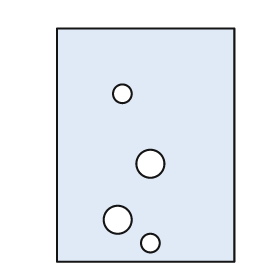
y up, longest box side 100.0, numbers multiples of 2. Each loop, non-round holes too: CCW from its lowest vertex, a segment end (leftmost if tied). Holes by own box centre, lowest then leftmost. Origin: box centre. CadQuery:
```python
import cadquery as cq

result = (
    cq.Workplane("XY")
    .moveTo(-38.0, -50.0)
    .lineTo(38.0, -50.0)
    .lineTo(38.0, 50.0)
    .lineTo(-38.0, 50.0)
    .close()
    .moveTo(2.0, -42.0)
    .circle(4.0)
    .moveTo(-12.0, -32.0)
    .circle(6.0)
    .moveTo(2.0, -8.0)
    .circle(6.0)
    .moveTo(-10.0, 22.0)
    .circle(4.0)
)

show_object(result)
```